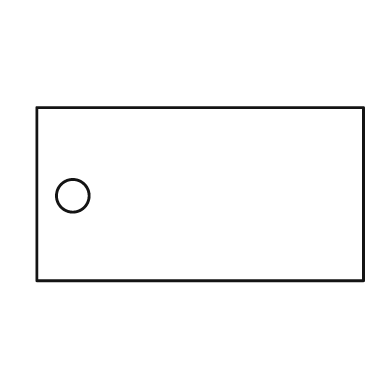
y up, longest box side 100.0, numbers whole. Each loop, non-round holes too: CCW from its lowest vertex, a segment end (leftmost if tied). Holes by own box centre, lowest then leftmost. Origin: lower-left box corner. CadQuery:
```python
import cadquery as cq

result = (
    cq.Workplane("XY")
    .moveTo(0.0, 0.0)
    .lineTo(100.0, 0.0)
    .lineTo(100.0, 53.0)
    .lineTo(0.0, 53.0)
    .close()
    .moveTo(11.0, 26.0)
    .circle(5.0)
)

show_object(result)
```